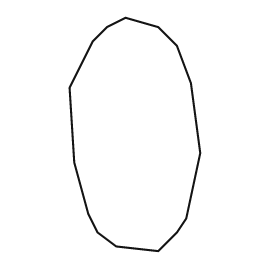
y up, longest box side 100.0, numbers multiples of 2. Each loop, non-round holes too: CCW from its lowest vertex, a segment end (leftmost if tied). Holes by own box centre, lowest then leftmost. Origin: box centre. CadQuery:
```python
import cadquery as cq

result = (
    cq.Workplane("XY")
    .moveTo(10.0, -50.0)
    .lineTo(18.0, -42.0)
    .lineTo(22.0, -36.0)
    .lineTo(28.0, -8.0)
    .lineTo(24.0, 22.0)
    .lineTo(18.0, 38.0)
    .lineTo(10.0, 46.0)
    .lineTo(-4.0, 50.0)
    .lineTo(-12.0, 46.0)
    .lineTo(-18.0, 40.0)
    .lineTo(-28.0, 20.0)
    .lineTo(-26.0, -12.0)
    .lineTo(-20.0, -34.0)
    .lineTo(-16.0, -42.0)
    .lineTo(-8.0, -48.0)
    .close()
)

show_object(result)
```